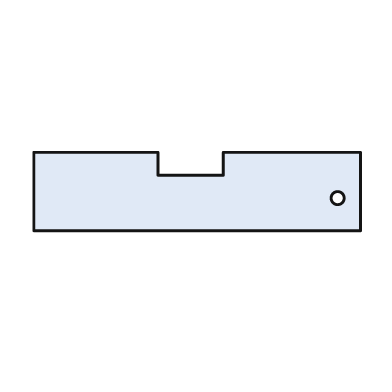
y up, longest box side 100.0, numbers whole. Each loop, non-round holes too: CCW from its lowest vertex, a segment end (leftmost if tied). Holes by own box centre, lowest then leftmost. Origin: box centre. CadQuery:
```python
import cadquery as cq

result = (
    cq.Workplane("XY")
    .moveTo(-50.0, -12.0)
    .lineTo(50.0, -12.0)
    .lineTo(50.0, 12.0)
    .lineTo(8.0, 12.0)
    .lineTo(8.0, 5.0)
    .lineTo(-12.0, 5.0)
    .lineTo(-12.0, 12.0)
    .lineTo(-50.0, 12.0)
    .close()
    .moveTo(43.0, -2.0)
    .circle(2.0)
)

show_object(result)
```